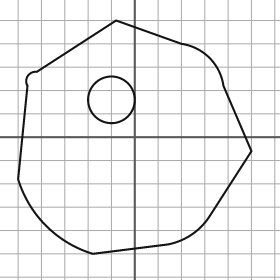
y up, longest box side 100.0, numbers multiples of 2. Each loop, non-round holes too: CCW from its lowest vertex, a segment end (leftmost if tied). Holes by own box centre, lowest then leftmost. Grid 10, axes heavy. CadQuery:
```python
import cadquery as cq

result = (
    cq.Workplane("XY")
    .moveTo(-18.0, -50.0)
    .lineTo(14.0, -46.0)
    .threePointArc((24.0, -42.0), (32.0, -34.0))
    .lineTo(50.0, -6.0)
    .lineTo(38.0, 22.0)
    .threePointArc((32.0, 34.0), (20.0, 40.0))
    .lineTo(-8.0, 50.0)
    .lineTo(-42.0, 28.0)
    .threePointArc((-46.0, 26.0), (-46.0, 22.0))
    .lineTo(-50.0, -18.0)
    .threePointArc((-38.0, -38.0), (-18.0, -50.0))
    .close()
    .moveTo(-10.0, 16.0)
    .circle(10.0)
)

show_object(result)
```